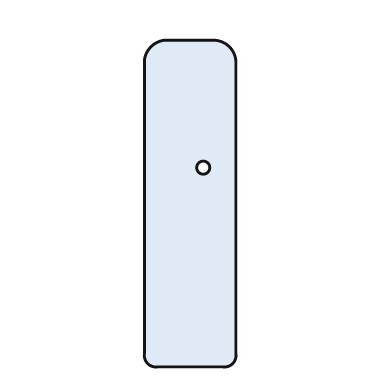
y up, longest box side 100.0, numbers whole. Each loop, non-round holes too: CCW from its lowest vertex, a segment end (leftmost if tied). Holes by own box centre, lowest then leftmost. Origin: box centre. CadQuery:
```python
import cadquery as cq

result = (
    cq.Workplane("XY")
    .moveTo(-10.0, -50.0)
    .lineTo(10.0, -50.0)
    .threePointArc((13.0, -49.0), (14.0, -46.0))
    .lineTo(14.0, 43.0)
    .threePointArc((12.0, 48.0), (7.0, 50.0))
    .lineTo(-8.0, 50.0)
    .threePointArc((-12.0, 48.0), (-14.0, 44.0))
    .lineTo(-14.0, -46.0)
    .threePointArc((-13.0, -49.0), (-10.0, -50.0))
    .close()
    .moveTo(4.0, 11.0)
    .circle(2.0)
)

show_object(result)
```